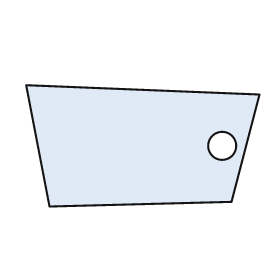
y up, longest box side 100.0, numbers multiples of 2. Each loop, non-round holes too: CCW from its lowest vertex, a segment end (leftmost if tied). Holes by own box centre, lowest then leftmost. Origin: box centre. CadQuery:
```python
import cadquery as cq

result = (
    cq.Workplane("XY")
    .moveTo(-40.0, -26.0)
    .lineTo(38.0, -24.0)
    .lineTo(50.0, 22.0)
    .lineTo(-50.0, 26.0)
    .close()
    .moveTo(34.0, 0.0)
    .circle(6.0)
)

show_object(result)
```